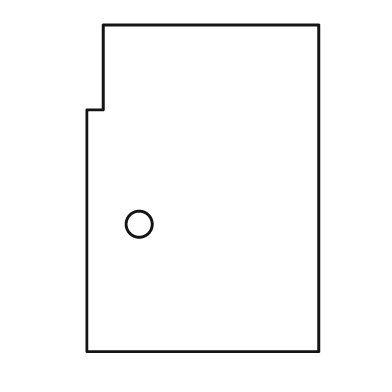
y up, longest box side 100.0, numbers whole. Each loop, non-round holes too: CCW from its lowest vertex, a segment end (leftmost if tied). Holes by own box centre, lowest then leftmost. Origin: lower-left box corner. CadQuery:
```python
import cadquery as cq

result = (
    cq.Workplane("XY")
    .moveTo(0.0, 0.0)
    .lineTo(71.0, 0.0)
    .lineTo(71.0, 100.0)
    .lineTo(5.0, 100.0)
    .lineTo(5.0, 74.0)
    .lineTo(0.0, 74.0)
    .close()
    .moveTo(16.0, 39.0)
    .circle(4.0)
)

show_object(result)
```